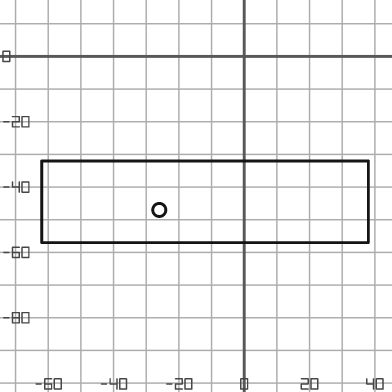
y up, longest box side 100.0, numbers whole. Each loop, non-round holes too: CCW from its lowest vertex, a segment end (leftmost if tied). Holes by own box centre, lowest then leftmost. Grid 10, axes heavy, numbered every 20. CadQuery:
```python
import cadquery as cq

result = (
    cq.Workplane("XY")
    .moveTo(-62.0, -57.0)
    .lineTo(38.0, -57.0)
    .lineTo(38.0, -32.0)
    .lineTo(-62.0, -32.0)
    .close()
    .moveTo(-26.0, -47.0)
    .circle(2.0)
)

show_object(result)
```